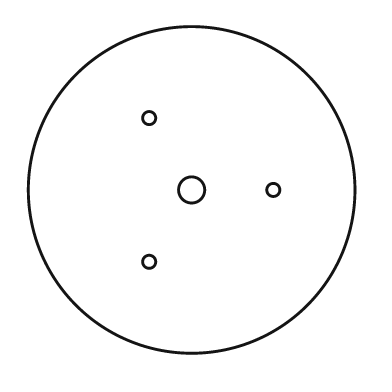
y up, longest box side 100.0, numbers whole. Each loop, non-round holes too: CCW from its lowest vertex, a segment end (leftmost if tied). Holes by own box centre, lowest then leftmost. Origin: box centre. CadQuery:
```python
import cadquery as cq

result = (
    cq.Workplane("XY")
    .moveTo(0.0, 0.0)
    .circle(50.0)
    .moveTo(-13.0, -22.0)
    .circle(2.0)
    .moveTo(0.0, 0.0)
    .circle(4.0)
    .moveTo(25.0, 0.0)
    .circle(2.0)
    .moveTo(-13.0, 22.0)
    .circle(2.0)
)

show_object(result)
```